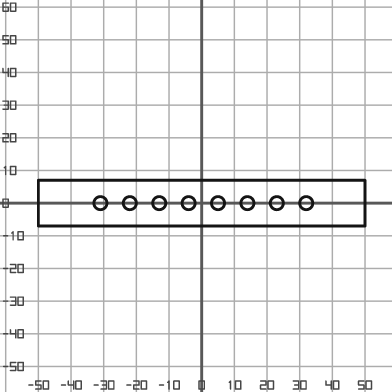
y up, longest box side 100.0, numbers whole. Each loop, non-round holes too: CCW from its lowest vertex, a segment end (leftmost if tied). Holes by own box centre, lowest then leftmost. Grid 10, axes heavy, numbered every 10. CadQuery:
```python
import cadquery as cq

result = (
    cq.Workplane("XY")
    .moveTo(-50.0, -7.0)
    .lineTo(50.0, -7.0)
    .lineTo(50.0, 7.0)
    .lineTo(-50.0, 7.0)
    .close()
    .moveTo(-31.0, 0.0)
    .circle(2.0)
    .moveTo(-22.0, 0.0)
    .circle(2.0)
    .moveTo(-13.0, 0.0)
    .circle(2.0)
    .moveTo(-4.0, 0.0)
    .circle(2.0)
    .moveTo(5.0, 0.0)
    .circle(2.0)
    .moveTo(14.0, 0.0)
    .circle(2.0)
    .moveTo(23.0, 0.0)
    .circle(2.0)
    .moveTo(32.0, 0.0)
    .circle(2.0)
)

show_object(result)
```